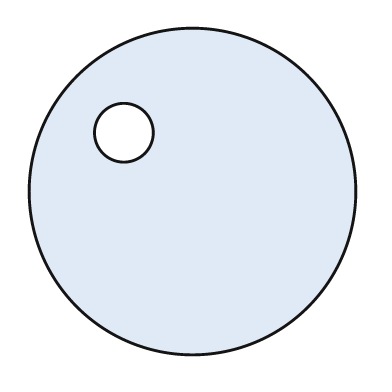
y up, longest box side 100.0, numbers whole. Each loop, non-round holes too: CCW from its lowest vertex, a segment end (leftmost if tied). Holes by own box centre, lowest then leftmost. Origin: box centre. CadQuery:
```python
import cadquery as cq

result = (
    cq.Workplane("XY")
    .moveTo(0.0, 0.0)
    .circle(50.0)
    .moveTo(-21.0, 18.0)
    .circle(9.0)
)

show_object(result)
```